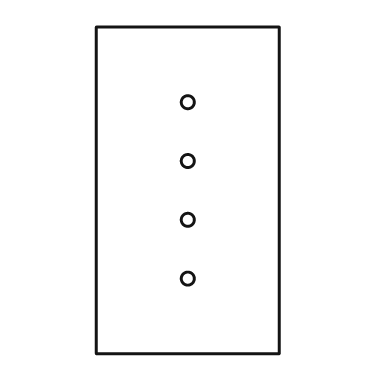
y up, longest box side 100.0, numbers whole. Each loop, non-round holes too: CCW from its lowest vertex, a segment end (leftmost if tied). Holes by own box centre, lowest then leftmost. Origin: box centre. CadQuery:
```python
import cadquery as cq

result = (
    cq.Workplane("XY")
    .moveTo(-28.0, -50.0)
    .lineTo(28.0, -50.0)
    .lineTo(28.0, 50.0)
    .lineTo(-28.0, 50.0)
    .close()
    .moveTo(0.0, -27.0)
    .circle(2.0)
    .moveTo(0.0, -9.0)
    .circle(2.0)
    .moveTo(0.0, 9.0)
    .circle(2.0)
    .moveTo(0.0, 27.0)
    .circle(2.0)
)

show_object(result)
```